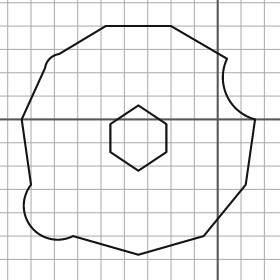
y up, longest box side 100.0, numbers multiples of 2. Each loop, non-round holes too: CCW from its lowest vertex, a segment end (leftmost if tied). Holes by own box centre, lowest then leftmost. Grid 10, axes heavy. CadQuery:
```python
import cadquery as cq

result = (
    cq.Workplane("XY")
    .moveTo(-34.0, -58.0)
    .lineTo(-6.0, -50.0)
    .lineTo(12.0, -28.0)
    .lineTo(16.0, 0.0)
    .threePointArc((4.0, 10.0), (4.0, 26.0))
    .lineTo(-20.0, 40.0)
    .lineTo(-48.0, 40.0)
    .lineTo(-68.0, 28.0)
    .threePointArc((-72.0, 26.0), (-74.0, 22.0))
    .lineTo(-84.0, 0.0)
    .lineTo(-80.0, -28.0)
    .threePointArc((-80.0, -46.0), (-62.0, -50.0))
    .close()
    .moveTo(-34.0, -22.0)
    .lineTo(-22.0, -14.0)
    .lineTo(-22.0, -2.0)
    .lineTo(-34.0, 6.0)
    .lineTo(-46.0, -2.0)
    .lineTo(-46.0, -14.0)
    .close()
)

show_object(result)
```